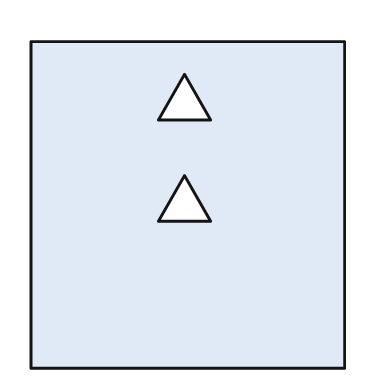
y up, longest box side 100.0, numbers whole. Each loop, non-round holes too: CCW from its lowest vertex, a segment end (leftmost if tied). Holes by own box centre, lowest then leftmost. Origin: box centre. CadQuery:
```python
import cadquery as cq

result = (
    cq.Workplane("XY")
    .moveTo(-48.0, -50.0)
    .lineTo(48.0, -50.0)
    .lineTo(48.0, 50.0)
    .lineTo(-48.0, 50.0)
    .close()
    .moveTo(-9.0, -5.0)
    .lineTo(7.0, -5.0)
    .lineTo(-1.0, 9.0)
    .close()
    .moveTo(-9.0, 26.0)
    .lineTo(7.0, 26.0)
    .lineTo(-1.0, 40.0)
    .close()
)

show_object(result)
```